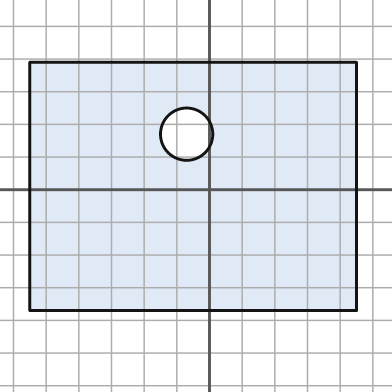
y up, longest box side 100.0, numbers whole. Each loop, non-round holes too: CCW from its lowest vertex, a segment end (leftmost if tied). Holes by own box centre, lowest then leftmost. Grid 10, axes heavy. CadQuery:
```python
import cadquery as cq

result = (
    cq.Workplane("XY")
    .moveTo(-55.0, -37.0)
    .lineTo(45.0, -37.0)
    .lineTo(45.0, 39.0)
    .lineTo(-55.0, 39.0)
    .close()
    .moveTo(-7.0, 17.0)
    .circle(8.0)
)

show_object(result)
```